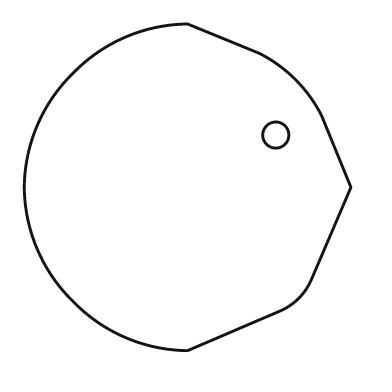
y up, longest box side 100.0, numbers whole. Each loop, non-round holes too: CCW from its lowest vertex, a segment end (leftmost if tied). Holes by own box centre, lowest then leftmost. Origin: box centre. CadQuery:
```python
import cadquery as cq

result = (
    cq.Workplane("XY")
    .moveTo(0.0, -50.0)
    .lineTo(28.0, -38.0)
    .threePointArc((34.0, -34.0), (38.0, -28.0))
    .lineTo(50.0, 0.0)
    .lineTo(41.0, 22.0)
    .threePointArc((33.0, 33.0), (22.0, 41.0))
    .lineTo(0.0, 50.0)
    .threePointArc((-19.0, 46.0), (-35.0, 35.0))
    .threePointArc((-46.0, 19.0), (-50.0, 0.0))
    .threePointArc((-46.0, -19.0), (-35.0, -35.0))
    .threePointArc((-19.0, -46.0), (0.0, -50.0))
    .close()
    .moveTo(27.0, 16.0)
    .circle(4.0)
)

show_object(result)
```